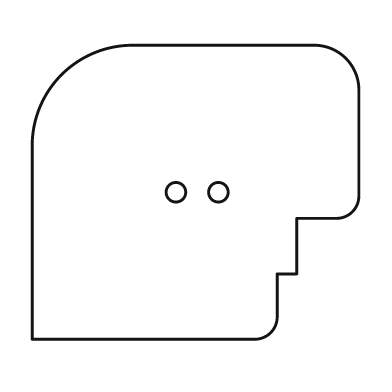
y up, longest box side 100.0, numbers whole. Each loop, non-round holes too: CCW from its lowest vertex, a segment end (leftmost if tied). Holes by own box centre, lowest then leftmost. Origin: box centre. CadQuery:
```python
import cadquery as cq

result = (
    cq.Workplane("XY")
    .moveTo(-50.0, -45.0)
    .lineTo(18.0, -45.0)
    .threePointArc((23.0, -43.0), (25.0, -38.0))
    .lineTo(25.0, -25.0)
    .lineTo(31.0, -25.0)
    .lineTo(31.0, -8.0)
    .lineTo(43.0, -8.0)
    .threePointArc((48.0, -6.0), (50.0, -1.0))
    .lineTo(50.0, 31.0)
    .threePointArc((46.0, 41.0), (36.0, 45.0))
    .lineTo(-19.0, 45.0)
    .threePointArc((-41.0, 36.0), (-50.0, 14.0))
    .close()
    .moveTo(-6.0, 0.0)
    .circle(3.0)
    .moveTo(7.0, 0.0)
    .circle(3.0)
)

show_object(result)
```